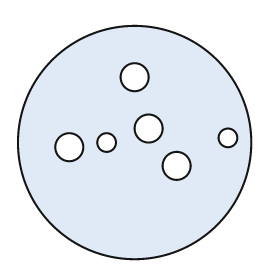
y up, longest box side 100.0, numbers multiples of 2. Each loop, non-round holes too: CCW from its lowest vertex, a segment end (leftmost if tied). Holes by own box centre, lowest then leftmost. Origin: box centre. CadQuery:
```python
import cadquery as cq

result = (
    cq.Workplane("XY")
    .moveTo(0.0, 0.0)
    .circle(50.0)
    .moveTo(18.0, -10.0)
    .circle(6.0)
    .moveTo(-28.0, -2.0)
    .circle(6.0)
    .moveTo(-12.0, 0.0)
    .circle(4.0)
    .moveTo(40.0, 2.0)
    .circle(4.0)
    .moveTo(6.0, 6.0)
    .circle(6.0)
    .moveTo(0.0, 28.0)
    .circle(6.0)
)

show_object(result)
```